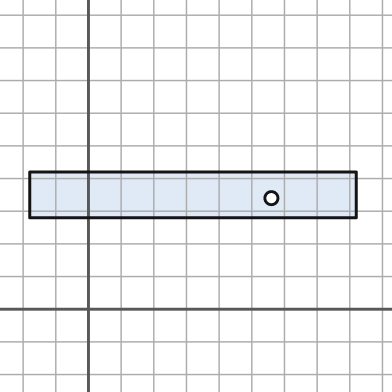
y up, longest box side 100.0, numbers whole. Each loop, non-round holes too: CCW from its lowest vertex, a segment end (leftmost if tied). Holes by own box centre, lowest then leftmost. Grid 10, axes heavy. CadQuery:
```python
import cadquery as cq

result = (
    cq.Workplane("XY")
    .moveTo(-18.0, 28.0)
    .lineTo(82.0, 28.0)
    .lineTo(82.0, 42.0)
    .lineTo(-18.0, 42.0)
    .close()
    .moveTo(56.0, 34.0)
    .circle(2.0)
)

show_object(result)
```